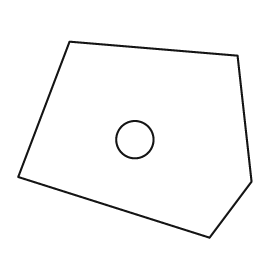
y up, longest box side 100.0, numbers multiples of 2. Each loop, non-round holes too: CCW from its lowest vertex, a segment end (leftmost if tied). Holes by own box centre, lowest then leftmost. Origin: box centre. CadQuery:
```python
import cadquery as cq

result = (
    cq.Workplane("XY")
    .moveTo(32.0, -42.0)
    .lineTo(50.0, -18.0)
    .lineTo(44.0, 36.0)
    .lineTo(-28.0, 42.0)
    .lineTo(-50.0, -16.0)
    .close()
    .moveTo(0.0, 0.0)
    .circle(8.0)
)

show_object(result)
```